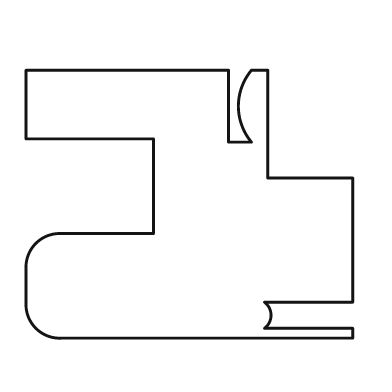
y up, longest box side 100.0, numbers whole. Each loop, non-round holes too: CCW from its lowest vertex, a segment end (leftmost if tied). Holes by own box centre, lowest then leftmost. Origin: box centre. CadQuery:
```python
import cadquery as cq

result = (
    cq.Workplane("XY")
    .moveTo(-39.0, -41.0)
    .lineTo(50.0, -41.0)
    .lineTo(50.0, -38.0)
    .lineTo(23.0, -38.0)
    .threePointArc((25.0, -34.0), (23.0, -30.0))
    .lineTo(50.0, -30.0)
    .lineTo(50.0, 8.0)
    .lineTo(24.0, 8.0)
    .lineTo(24.0, 41.0)
    .lineTo(19.0, 41.0)
    .threePointArc((15.0, 30.0), (19.0, 19.0))
    .lineTo(12.0, 19.0)
    .lineTo(12.0, 41.0)
    .lineTo(-50.0, 41.0)
    .lineTo(-50.0, 20.0)
    .lineTo(-11.0, 20.0)
    .lineTo(-11.0, -9.0)
    .lineTo(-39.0, -9.0)
    .threePointArc((-47.0, -12.0), (-50.0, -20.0))
    .lineTo(-50.0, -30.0)
    .threePointArc((-47.0, -38.0), (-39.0, -41.0))
    .close()
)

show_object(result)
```